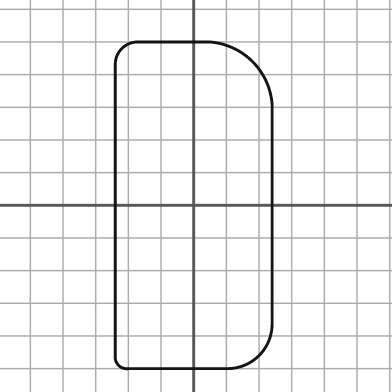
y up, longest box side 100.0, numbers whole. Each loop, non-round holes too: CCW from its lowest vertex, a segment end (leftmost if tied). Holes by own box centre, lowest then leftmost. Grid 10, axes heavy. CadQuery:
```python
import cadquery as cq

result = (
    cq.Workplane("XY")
    .moveTo(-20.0, -50.0)
    .lineTo(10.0, -50.0)
    .threePointArc((20.0, -46.0), (24.0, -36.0))
    .lineTo(24.0, 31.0)
    .threePointArc((18.0, 44.0), (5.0, 50.0))
    .lineTo(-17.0, 50.0)
    .threePointArc((-22.0, 48.0), (-24.0, 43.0))
    .lineTo(-24.0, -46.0)
    .threePointArc((-23.0, -49.0), (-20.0, -50.0))
    .close()
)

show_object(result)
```